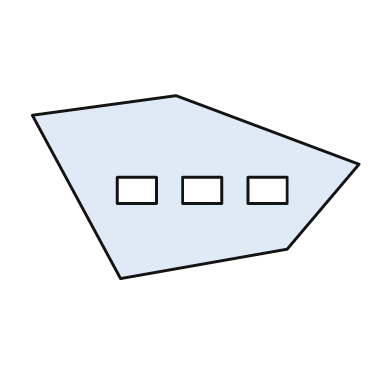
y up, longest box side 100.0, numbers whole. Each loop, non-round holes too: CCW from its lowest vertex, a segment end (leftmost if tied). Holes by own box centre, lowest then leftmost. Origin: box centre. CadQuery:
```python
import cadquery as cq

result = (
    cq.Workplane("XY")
    .moveTo(-23.0, -28.0)
    .lineTo(28.0, -19.0)
    .lineTo(50.0, 7.0)
    .lineTo(-6.0, 28.0)
    .lineTo(-50.0, 22.0)
    .close()
    .moveTo(-24.0, -5.0)
    .lineTo(-12.0, -5.0)
    .lineTo(-12.0, 3.0)
    .lineTo(-24.0, 3.0)
    .close()
    .moveTo(-4.0, -5.0)
    .lineTo(8.0, -5.0)
    .lineTo(8.0, 3.0)
    .lineTo(-4.0, 3.0)
    .close()
    .moveTo(16.0, -5.0)
    .lineTo(28.0, -5.0)
    .lineTo(28.0, 3.0)
    .lineTo(16.0, 3.0)
    .close()
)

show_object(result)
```